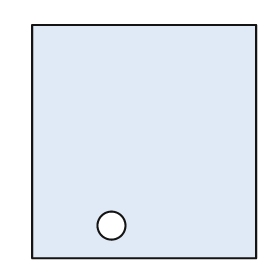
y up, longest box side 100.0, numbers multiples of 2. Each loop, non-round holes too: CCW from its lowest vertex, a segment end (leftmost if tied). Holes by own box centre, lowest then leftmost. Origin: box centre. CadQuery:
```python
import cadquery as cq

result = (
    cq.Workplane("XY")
    .moveTo(-48.0, -50.0)
    .lineTo(48.0, -50.0)
    .lineTo(48.0, 50.0)
    .lineTo(-48.0, 50.0)
    .close()
    .moveTo(-14.0, -36.0)
    .circle(6.0)
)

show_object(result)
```